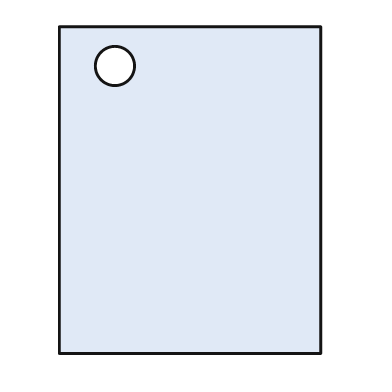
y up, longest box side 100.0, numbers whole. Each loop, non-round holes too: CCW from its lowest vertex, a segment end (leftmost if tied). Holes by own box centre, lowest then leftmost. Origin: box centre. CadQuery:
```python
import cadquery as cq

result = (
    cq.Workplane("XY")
    .moveTo(-40.0, -50.0)
    .lineTo(40.0, -50.0)
    .lineTo(40.0, 50.0)
    .lineTo(-40.0, 50.0)
    .close()
    .moveTo(-23.0, 38.0)
    .circle(6.0)
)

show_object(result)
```